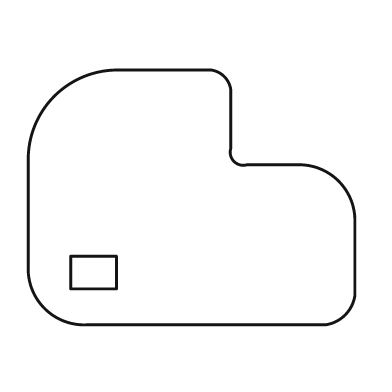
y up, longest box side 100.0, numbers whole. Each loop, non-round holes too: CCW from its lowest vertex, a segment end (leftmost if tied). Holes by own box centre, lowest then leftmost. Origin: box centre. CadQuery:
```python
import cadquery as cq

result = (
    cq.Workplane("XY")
    .moveTo(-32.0, -39.0)
    .lineTo(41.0, -39.0)
    .threePointArc((47.0, -36.0), (50.0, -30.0))
    .lineTo(50.0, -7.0)
    .threePointArc((45.0, 5.0), (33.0, 10.0))
    .lineTo(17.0, 10.0)
    .threePointArc((13.0, 11.0), (12.0, 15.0))
    .lineTo(12.0, 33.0)
    .threePointArc((10.0, 37.0), (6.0, 39.0))
    .lineTo(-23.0, 39.0)
    .threePointArc((-42.0, 31.0), (-50.0, 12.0))
    .lineTo(-50.0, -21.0)
    .threePointArc((-45.0, -34.0), (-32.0, -39.0))
    .close()
    .moveTo(-37.0, -28.0)
    .lineTo(-23.0, -28.0)
    .lineTo(-23.0, -18.0)
    .lineTo(-37.0, -18.0)
    .close()
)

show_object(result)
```